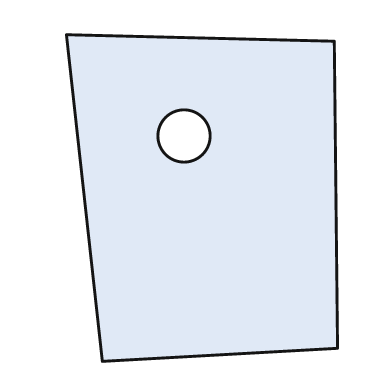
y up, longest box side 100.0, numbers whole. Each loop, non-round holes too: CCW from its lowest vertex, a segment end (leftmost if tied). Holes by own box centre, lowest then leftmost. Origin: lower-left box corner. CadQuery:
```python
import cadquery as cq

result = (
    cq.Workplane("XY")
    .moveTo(11.0, 0.0)
    .lineTo(83.0, 4.0)
    .lineTo(82.0, 98.0)
    .lineTo(0.0, 100.0)
    .close()
    .moveTo(36.0, 69.0)
    .circle(8.0)
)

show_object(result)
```